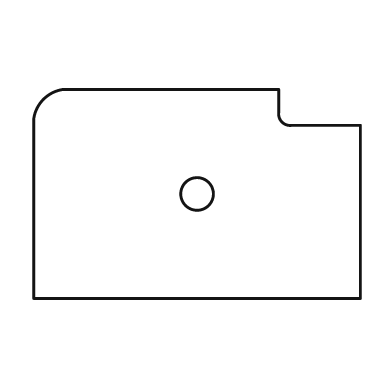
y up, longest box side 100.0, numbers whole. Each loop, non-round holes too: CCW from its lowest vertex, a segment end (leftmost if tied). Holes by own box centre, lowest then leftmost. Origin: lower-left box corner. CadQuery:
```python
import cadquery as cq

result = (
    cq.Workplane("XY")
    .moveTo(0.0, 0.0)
    .lineTo(100.0, 0.0)
    .lineTo(100.0, 53.0)
    .lineTo(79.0, 53.0)
    .threePointArc((76.0, 54.0), (75.0, 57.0))
    .lineTo(75.0, 64.0)
    .lineTo(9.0, 64.0)
    .threePointArc((3.0, 61.0), (0.0, 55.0))
    .close()
    .moveTo(50.0, 32.0)
    .circle(5.0)
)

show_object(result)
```